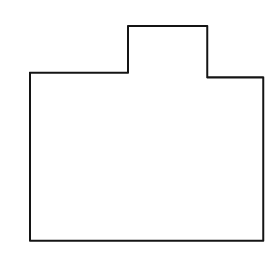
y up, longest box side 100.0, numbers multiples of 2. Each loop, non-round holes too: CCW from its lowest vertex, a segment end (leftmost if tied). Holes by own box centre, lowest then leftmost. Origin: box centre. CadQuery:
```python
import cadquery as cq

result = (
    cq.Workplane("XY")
    .moveTo(-50.0, -46.0)
    .lineTo(50.0, -46.0)
    .lineTo(50.0, 24.0)
    .lineTo(26.0, 24.0)
    .lineTo(26.0, 46.0)
    .lineTo(-8.0, 46.0)
    .lineTo(-8.0, 26.0)
    .lineTo(-50.0, 26.0)
    .close()
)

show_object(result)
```